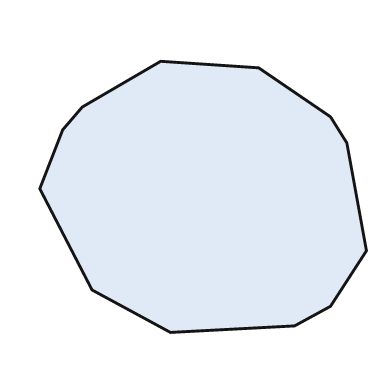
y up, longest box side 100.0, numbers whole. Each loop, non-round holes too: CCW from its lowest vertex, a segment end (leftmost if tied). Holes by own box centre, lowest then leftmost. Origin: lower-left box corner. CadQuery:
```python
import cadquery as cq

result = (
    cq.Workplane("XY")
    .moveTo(40.0, 0.0)
    .lineTo(78.0, 2.0)
    .lineTo(89.0, 8.0)
    .lineTo(100.0, 25.0)
    .lineTo(94.0, 58.0)
    .lineTo(89.0, 66.0)
    .lineTo(67.0, 81.0)
    .lineTo(37.0, 83.0)
    .lineTo(13.0, 69.0)
    .lineTo(7.0, 62.0)
    .lineTo(0.0, 44.0)
    .lineTo(16.0, 13.0)
    .close()
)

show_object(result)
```